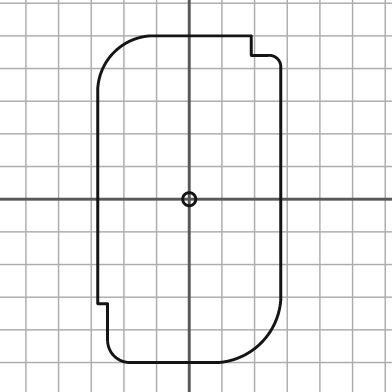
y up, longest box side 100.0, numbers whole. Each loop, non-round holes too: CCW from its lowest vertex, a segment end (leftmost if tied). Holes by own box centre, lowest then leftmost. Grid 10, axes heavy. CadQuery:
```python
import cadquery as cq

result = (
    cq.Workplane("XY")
    .moveTo(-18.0, -50.0)
    .lineTo(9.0, -50.0)
    .threePointArc((22.0, -44.0), (28.0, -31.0))
    .lineTo(28.0, 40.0)
    .threePointArc((27.0, 43.0), (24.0, 44.0))
    .lineTo(19.0, 44.0)
    .lineTo(19.0, 50.0)
    .lineTo(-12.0, 50.0)
    .threePointArc((-23.0, 45.0), (-28.0, 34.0))
    .lineTo(-28.0, -32.0)
    .lineTo(-25.0, -32.0)
    .lineTo(-25.0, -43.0)
    .threePointArc((-23.0, -48.0), (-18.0, -50.0))
    .close()
    .moveTo(0.0, 0.0)
    .circle(2.0)
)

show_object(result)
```